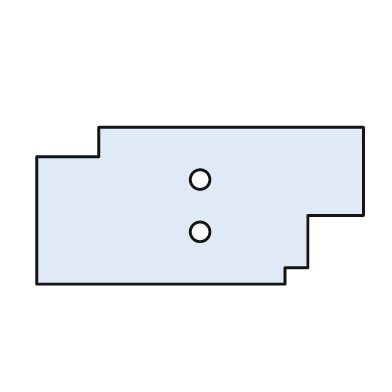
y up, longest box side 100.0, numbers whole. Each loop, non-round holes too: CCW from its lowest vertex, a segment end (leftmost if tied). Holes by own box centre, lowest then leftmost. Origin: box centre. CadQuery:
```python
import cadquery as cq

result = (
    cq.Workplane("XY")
    .moveTo(-50.0, -24.0)
    .lineTo(26.0, -24.0)
    .lineTo(26.0, -19.0)
    .lineTo(33.0, -19.0)
    .lineTo(33.0, -3.0)
    .lineTo(50.0, -3.0)
    .lineTo(50.0, 24.0)
    .lineTo(-31.0, 24.0)
    .lineTo(-31.0, 15.0)
    .lineTo(-50.0, 15.0)
    .close()
    .moveTo(0.0, -8.0)
    .circle(3.0)
    .moveTo(0.0, 8.0)
    .circle(3.0)
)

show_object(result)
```